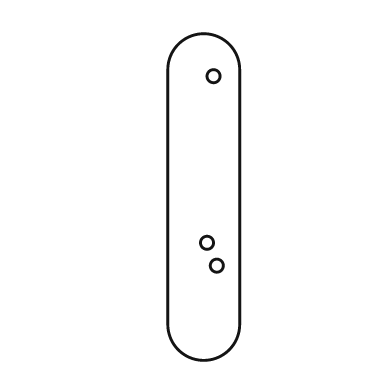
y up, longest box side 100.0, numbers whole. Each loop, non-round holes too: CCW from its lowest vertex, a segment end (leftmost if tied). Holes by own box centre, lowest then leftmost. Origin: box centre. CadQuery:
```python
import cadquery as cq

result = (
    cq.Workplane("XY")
    .moveTo(-11.0, -39.0)
    .threePointArc((0.0, -50.0), (11.0, -39.0))
    .lineTo(11.0, 39.0)
    .threePointArc((0.0, 50.0), (-11.0, 39.0))
    .close()
    .moveTo(4.0, -21.0)
    .circle(2.0)
    .moveTo(1.0, -14.0)
    .circle(2.0)
    .moveTo(3.0, 37.0)
    .circle(2.0)
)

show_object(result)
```